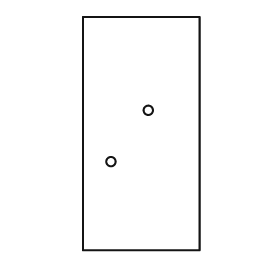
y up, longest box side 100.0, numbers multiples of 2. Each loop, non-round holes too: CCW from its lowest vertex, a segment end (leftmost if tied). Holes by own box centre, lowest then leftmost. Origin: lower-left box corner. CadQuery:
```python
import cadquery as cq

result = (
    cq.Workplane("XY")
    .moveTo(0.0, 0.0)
    .lineTo(50.0, 0.0)
    .lineTo(50.0, 100.0)
    .lineTo(0.0, 100.0)
    .close()
    .moveTo(12.0, 38.0)
    .circle(2.0)
    .moveTo(28.0, 60.0)
    .circle(2.0)
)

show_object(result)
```